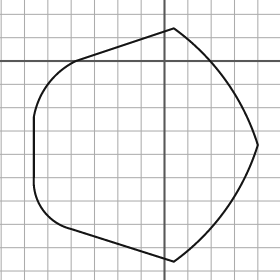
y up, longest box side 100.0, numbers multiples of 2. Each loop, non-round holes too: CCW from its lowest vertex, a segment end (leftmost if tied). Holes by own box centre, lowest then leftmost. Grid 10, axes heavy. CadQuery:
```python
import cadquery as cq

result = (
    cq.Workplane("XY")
    .moveTo(4.0, -86.0)
    .threePointArc((26.0, -64.0), (40.0, -36.0))
    .threePointArc((26.0, -8.0), (4.0, 14.0))
    .lineTo(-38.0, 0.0)
    .threePointArc((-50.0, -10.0), (-56.0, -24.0))
    .lineTo(-56.0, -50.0)
    .threePointArc((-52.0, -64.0), (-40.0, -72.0))
    .close()
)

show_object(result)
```